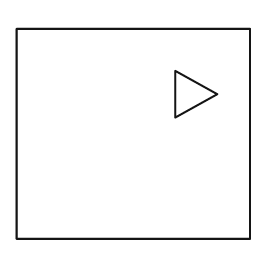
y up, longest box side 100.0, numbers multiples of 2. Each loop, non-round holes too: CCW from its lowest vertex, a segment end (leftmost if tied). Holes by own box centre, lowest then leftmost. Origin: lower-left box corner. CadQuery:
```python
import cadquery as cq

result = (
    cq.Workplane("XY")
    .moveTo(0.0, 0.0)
    .lineTo(100.0, 0.0)
    .lineTo(100.0, 90.0)
    .lineTo(0.0, 90.0)
    .close()
    .moveTo(68.0, 52.0)
    .lineTo(86.0, 62.0)
    .lineTo(68.0, 72.0)
    .close()
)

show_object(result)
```